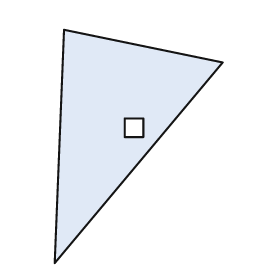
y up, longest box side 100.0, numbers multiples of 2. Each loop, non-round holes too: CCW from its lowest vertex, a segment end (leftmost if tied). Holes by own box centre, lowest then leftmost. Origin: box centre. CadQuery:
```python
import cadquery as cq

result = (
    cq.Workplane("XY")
    .moveTo(-36.0, -50.0)
    .lineTo(36.0, 36.0)
    .lineTo(-32.0, 50.0)
    .close()
    .moveTo(-6.0, 4.0)
    .lineTo(2.0, 4.0)
    .lineTo(2.0, 12.0)
    .lineTo(-6.0, 12.0)
    .close()
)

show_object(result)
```